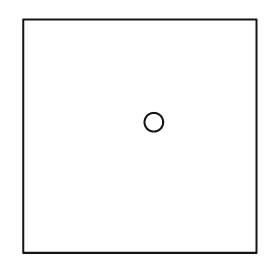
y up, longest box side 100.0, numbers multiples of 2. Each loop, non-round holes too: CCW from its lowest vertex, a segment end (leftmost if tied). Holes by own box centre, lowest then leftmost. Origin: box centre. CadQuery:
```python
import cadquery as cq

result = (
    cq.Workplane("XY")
    .moveTo(-50.0, -50.0)
    .lineTo(50.0, -50.0)
    .lineTo(50.0, 50.0)
    .lineTo(-50.0, 50.0)
    .close()
    .moveTo(6.0, 6.0)
    .circle(4.0)
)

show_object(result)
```